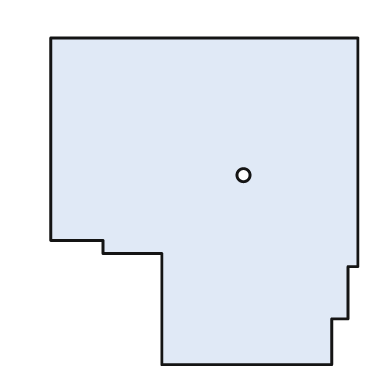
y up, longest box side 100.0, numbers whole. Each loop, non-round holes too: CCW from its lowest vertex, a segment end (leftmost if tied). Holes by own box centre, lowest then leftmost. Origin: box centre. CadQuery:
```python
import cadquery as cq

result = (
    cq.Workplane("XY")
    .moveTo(-13.0, -50.0)
    .lineTo(39.0, -50.0)
    .lineTo(39.0, -36.0)
    .lineTo(44.0, -36.0)
    .lineTo(44.0, -20.0)
    .lineTo(47.0, -20.0)
    .lineTo(47.0, 50.0)
    .lineTo(-47.0, 50.0)
    .lineTo(-47.0, -12.0)
    .lineTo(-31.0, -12.0)
    .lineTo(-31.0, -16.0)
    .lineTo(-13.0, -16.0)
    .close()
    .moveTo(12.0, 8.0)
    .circle(2.0)
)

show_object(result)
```